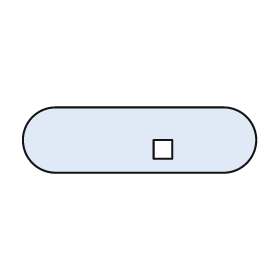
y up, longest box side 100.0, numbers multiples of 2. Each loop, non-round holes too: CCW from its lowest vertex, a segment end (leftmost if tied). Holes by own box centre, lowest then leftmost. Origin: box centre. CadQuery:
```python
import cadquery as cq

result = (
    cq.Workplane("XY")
    .moveTo(-36.0, -14.0)
    .lineTo(36.0, -14.0)
    .threePointArc((50.0, 0.0), (36.0, 14.0))
    .lineTo(-36.0, 14.0)
    .threePointArc((-50.0, 0.0), (-36.0, -14.0))
    .close()
    .moveTo(6.0, -8.0)
    .lineTo(14.0, -8.0)
    .lineTo(14.0, 0.0)
    .lineTo(6.0, 0.0)
    .close()
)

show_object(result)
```